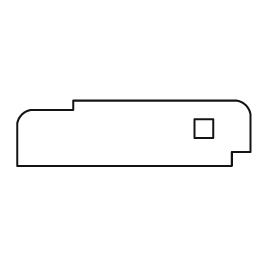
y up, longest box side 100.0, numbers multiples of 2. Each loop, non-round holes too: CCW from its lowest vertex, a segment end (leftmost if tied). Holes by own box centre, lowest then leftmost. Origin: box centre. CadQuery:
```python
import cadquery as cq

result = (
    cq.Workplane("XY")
    .moveTo(-50.0, -14.0)
    .lineTo(42.0, -14.0)
    .lineTo(42.0, -8.0)
    .lineTo(50.0, -8.0)
    .lineTo(50.0, 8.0)
    .threePointArc((48.0, 12.0), (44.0, 14.0))
    .lineTo(-26.0, 14.0)
    .lineTo(-26.0, 10.0)
    .lineTo(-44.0, 10.0)
    .threePointArc((-48.0, 8.0), (-50.0, 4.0))
    .close()
    .moveTo(26.0, -2.0)
    .lineTo(34.0, -2.0)
    .lineTo(34.0, 6.0)
    .lineTo(26.0, 6.0)
    .close()
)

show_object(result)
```